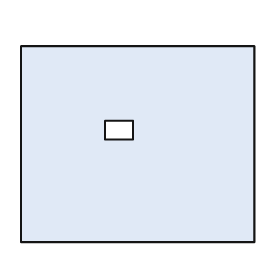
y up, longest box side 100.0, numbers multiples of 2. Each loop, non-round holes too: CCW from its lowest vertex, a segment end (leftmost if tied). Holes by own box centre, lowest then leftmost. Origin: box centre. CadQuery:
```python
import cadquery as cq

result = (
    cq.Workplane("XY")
    .moveTo(-50.0, -42.0)
    .lineTo(50.0, -42.0)
    .lineTo(50.0, 42.0)
    .lineTo(-50.0, 42.0)
    .close()
    .moveTo(-14.0, 2.0)
    .lineTo(-2.0, 2.0)
    .lineTo(-2.0, 10.0)
    .lineTo(-14.0, 10.0)
    .close()
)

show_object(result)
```